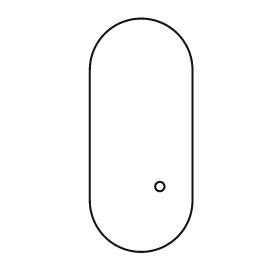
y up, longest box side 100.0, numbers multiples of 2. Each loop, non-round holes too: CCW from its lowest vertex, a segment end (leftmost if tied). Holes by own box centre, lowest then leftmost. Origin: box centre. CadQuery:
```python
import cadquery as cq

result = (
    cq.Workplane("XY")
    .moveTo(-22.0, -28.0)
    .threePointArc((0.0, -50.0), (22.0, -28.0))
    .lineTo(22.0, 28.0)
    .threePointArc((0.0, 50.0), (-22.0, 28.0))
    .close()
    .moveTo(8.0, -22.0)
    .circle(2.0)
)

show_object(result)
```